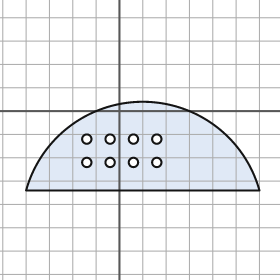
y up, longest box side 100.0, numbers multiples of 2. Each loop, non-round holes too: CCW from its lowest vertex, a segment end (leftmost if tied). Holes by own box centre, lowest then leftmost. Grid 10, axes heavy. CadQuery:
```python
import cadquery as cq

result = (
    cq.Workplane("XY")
    .moveTo(-40.0, -34.0)
    .lineTo(60.0, -34.0)
    .threePointArc((10.0, 4.0), (-40.0, -34.0))
    .close()
    .moveTo(-14.0, -22.0)
    .circle(2.0)
    .moveTo(-4.0, -22.0)
    .circle(2.0)
    .moveTo(6.0, -22.0)
    .circle(2.0)
    .moveTo(16.0, -22.0)
    .circle(2.0)
    .moveTo(-14.0, -12.0)
    .circle(2.0)
    .moveTo(-4.0, -12.0)
    .circle(2.0)
    .moveTo(6.0, -12.0)
    .circle(2.0)
    .moveTo(16.0, -12.0)
    .circle(2.0)
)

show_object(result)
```